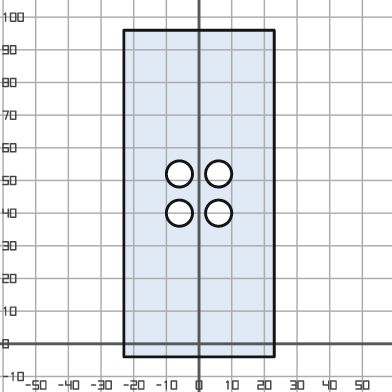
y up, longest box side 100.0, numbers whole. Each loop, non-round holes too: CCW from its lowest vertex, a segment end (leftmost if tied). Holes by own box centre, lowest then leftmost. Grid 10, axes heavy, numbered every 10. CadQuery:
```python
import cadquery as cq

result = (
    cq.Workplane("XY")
    .moveTo(-23.0, -4.0)
    .lineTo(23.0, -4.0)
    .lineTo(23.0, 96.0)
    .lineTo(-23.0, 96.0)
    .close()
    .moveTo(-6.0, 40.0)
    .circle(4.0)
    .moveTo(6.0, 40.0)
    .circle(4.0)
    .moveTo(-6.0, 52.0)
    .circle(4.0)
    .moveTo(6.0, 52.0)
    .circle(4.0)
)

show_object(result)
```